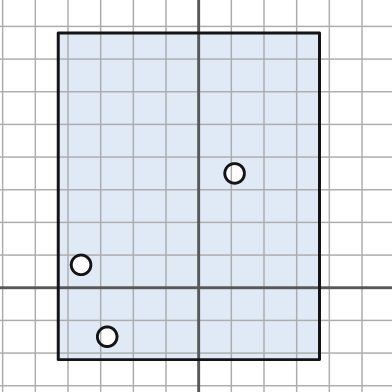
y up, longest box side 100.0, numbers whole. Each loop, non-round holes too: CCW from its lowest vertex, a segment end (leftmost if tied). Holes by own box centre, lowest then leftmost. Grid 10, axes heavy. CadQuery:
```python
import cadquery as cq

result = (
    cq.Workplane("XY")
    .moveTo(-43.0, -22.0)
    .lineTo(37.0, -22.0)
    .lineTo(37.0, 78.0)
    .lineTo(-43.0, 78.0)
    .close()
    .moveTo(-28.0, -15.0)
    .circle(3.0)
    .moveTo(-36.0, 7.0)
    .circle(3.0)
    .moveTo(11.0, 35.0)
    .circle(3.0)
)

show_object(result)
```